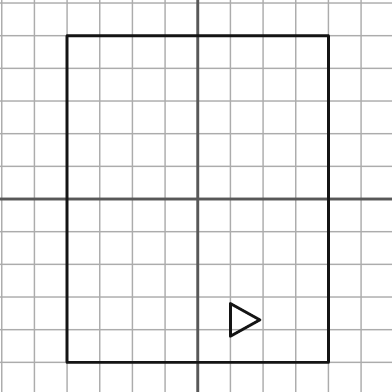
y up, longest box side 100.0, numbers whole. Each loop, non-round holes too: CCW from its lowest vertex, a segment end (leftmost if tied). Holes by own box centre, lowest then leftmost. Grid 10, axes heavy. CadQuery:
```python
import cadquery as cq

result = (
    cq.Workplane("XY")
    .moveTo(-40.0, -50.0)
    .lineTo(40.0, -50.0)
    .lineTo(40.0, 50.0)
    .lineTo(-40.0, 50.0)
    .close()
    .moveTo(10.0, -42.0)
    .lineTo(19.0, -37.0)
    .lineTo(10.0, -32.0)
    .close()
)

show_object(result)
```